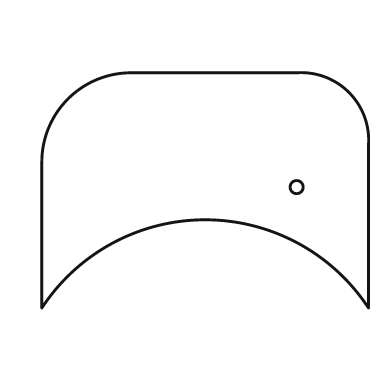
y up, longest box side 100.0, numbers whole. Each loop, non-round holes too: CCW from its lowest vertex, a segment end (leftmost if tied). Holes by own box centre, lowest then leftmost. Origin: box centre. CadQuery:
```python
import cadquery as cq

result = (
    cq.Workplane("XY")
    .moveTo(-50.0, -36.0)
    .threePointArc((0.0, -9.0), (50.0, -36.0))
    .lineTo(50.0, 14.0)
    .threePointArc((44.0, 30.0), (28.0, 36.0))
    .lineTo(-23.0, 36.0)
    .threePointArc((-42.0, 28.0), (-50.0, 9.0))
    .close()
    .moveTo(28.0, 1.0)
    .circle(2.0)
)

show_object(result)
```